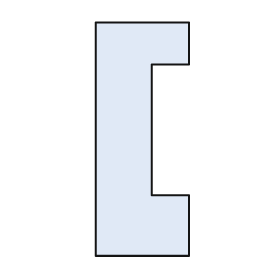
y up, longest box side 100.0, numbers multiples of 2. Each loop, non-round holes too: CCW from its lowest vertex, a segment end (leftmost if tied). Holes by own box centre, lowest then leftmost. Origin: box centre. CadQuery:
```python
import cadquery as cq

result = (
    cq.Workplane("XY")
    .moveTo(-20.0, -50.0)
    .lineTo(20.0, -50.0)
    .lineTo(20.0, -24.0)
    .lineTo(4.0, -24.0)
    .lineTo(4.0, 32.0)
    .lineTo(20.0, 32.0)
    .lineTo(20.0, 50.0)
    .lineTo(-20.0, 50.0)
    .close()
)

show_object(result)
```